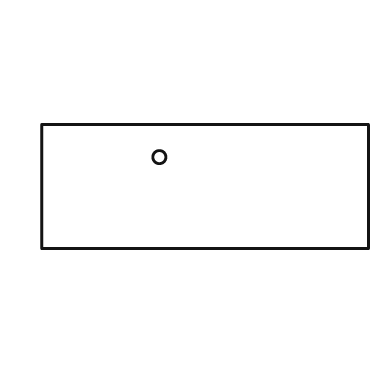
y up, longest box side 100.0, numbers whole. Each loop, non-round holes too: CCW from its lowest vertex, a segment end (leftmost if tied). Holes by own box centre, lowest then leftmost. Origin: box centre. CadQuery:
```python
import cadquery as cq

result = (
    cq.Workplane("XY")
    .moveTo(-50.0, -19.0)
    .lineTo(50.0, -19.0)
    .lineTo(50.0, 19.0)
    .lineTo(-50.0, 19.0)
    .close()
    .moveTo(-14.0, 9.0)
    .circle(2.0)
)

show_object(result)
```